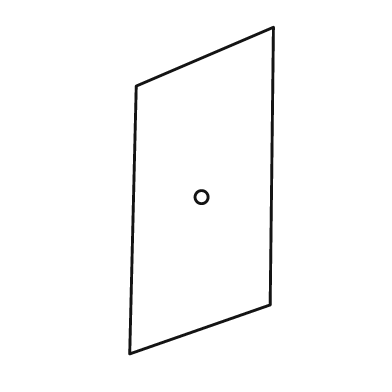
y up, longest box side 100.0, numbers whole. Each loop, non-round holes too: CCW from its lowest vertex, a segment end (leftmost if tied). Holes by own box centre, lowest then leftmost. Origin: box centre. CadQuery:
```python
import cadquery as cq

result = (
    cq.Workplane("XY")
    .moveTo(-22.0, -50.0)
    .lineTo(21.0, -35.0)
    .lineTo(22.0, 50.0)
    .lineTo(-20.0, 32.0)
    .close()
    .moveTo(0.0, -2.0)
    .circle(2.0)
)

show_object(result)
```